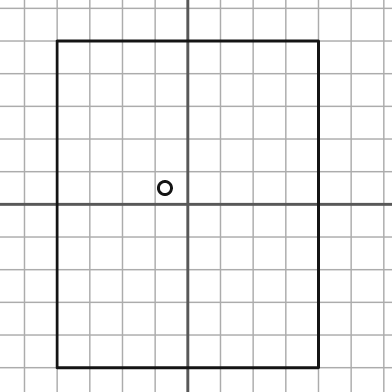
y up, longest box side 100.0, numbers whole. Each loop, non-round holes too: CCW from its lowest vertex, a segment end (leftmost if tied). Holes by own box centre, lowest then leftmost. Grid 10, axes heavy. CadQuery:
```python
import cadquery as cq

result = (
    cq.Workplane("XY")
    .moveTo(-40.0, -50.0)
    .lineTo(40.0, -50.0)
    .lineTo(40.0, 50.0)
    .lineTo(-40.0, 50.0)
    .close()
    .moveTo(-7.0, 5.0)
    .circle(2.0)
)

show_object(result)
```